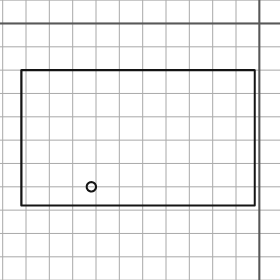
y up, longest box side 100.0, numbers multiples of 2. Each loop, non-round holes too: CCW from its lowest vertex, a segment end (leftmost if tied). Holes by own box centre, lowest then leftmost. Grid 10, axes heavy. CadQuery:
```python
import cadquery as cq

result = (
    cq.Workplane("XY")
    .moveTo(-102.0, -78.0)
    .lineTo(-2.0, -78.0)
    .lineTo(-2.0, -20.0)
    .lineTo(-102.0, -20.0)
    .close()
    .moveTo(-72.0, -70.0)
    .circle(2.0)
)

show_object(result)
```